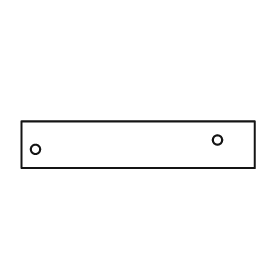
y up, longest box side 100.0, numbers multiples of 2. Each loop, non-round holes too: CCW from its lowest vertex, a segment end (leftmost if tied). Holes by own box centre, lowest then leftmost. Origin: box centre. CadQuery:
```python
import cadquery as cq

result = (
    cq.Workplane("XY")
    .moveTo(-50.0, -10.0)
    .lineTo(50.0, -10.0)
    .lineTo(50.0, 10.0)
    .lineTo(-50.0, 10.0)
    .close()
    .moveTo(-44.0, -2.0)
    .circle(2.0)
    .moveTo(34.0, 2.0)
    .circle(2.0)
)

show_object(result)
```